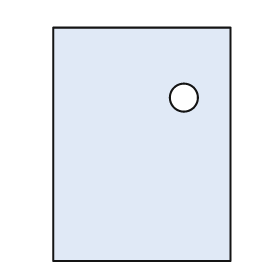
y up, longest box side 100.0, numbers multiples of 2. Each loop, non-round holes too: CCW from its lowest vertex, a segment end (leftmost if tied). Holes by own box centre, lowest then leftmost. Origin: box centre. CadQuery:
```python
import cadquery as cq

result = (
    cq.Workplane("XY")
    .moveTo(-38.0, -50.0)
    .lineTo(38.0, -50.0)
    .lineTo(38.0, 50.0)
    .lineTo(-38.0, 50.0)
    .close()
    .moveTo(18.0, 20.0)
    .circle(6.0)
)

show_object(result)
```